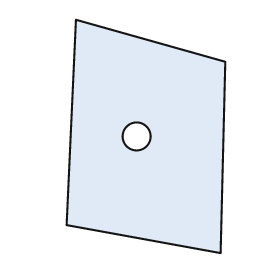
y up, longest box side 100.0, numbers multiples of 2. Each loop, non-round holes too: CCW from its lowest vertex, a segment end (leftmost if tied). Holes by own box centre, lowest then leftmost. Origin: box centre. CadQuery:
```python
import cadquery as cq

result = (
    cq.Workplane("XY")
    .moveTo(32.0, -50.0)
    .lineTo(34.0, 32.0)
    .lineTo(-30.0, 50.0)
    .lineTo(-34.0, -38.0)
    .close()
    .moveTo(-4.0, 0.0)
    .circle(6.0)
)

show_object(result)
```